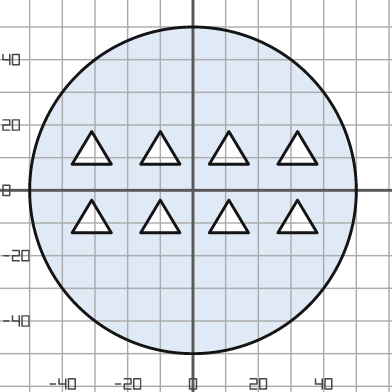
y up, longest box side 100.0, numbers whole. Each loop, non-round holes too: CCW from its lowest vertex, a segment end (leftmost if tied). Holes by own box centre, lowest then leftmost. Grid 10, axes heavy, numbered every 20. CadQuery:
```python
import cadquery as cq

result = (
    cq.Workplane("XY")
    .moveTo(0.0, 0.0)
    .circle(50.0)
    .moveTo(-37.0, -13.0)
    .lineTo(-25.0, -13.0)
    .lineTo(-31.0, -3.0)
    .close()
    .moveTo(-16.0, -13.0)
    .lineTo(-4.0, -13.0)
    .lineTo(-10.0, -3.0)
    .close()
    .moveTo(5.0, -13.0)
    .lineTo(17.0, -13.0)
    .lineTo(11.0, -3.0)
    .close()
    .moveTo(26.0, -13.0)
    .lineTo(38.0, -13.0)
    .lineTo(32.0, -3.0)
    .close()
    .moveTo(-37.0, 8.0)
    .lineTo(-25.0, 8.0)
    .lineTo(-31.0, 18.0)
    .close()
    .moveTo(-16.0, 8.0)
    .lineTo(-4.0, 8.0)
    .lineTo(-10.0, 18.0)
    .close()
    .moveTo(5.0, 8.0)
    .lineTo(17.0, 8.0)
    .lineTo(11.0, 18.0)
    .close()
    .moveTo(26.0, 8.0)
    .lineTo(38.0, 8.0)
    .lineTo(32.0, 18.0)
    .close()
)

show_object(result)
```